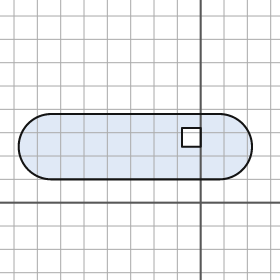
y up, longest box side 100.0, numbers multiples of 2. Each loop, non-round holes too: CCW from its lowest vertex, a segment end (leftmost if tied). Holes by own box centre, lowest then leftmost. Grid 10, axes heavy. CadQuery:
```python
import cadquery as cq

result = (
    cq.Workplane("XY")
    .moveTo(-64.0, 10.0)
    .lineTo(8.0, 10.0)
    .threePointArc((22.0, 24.0), (8.0, 38.0))
    .lineTo(-64.0, 38.0)
    .threePointArc((-78.0, 24.0), (-64.0, 10.0))
    .close()
    .moveTo(-8.0, 24.0)
    .lineTo(0.0, 24.0)
    .lineTo(0.0, 32.0)
    .lineTo(-8.0, 32.0)
    .close()
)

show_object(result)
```